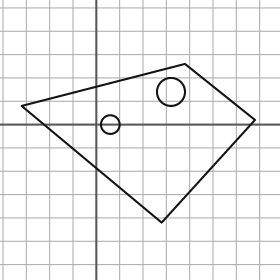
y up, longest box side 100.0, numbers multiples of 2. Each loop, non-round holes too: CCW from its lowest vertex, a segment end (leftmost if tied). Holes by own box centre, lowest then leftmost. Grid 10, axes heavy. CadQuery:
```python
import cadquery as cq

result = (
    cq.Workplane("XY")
    .moveTo(28.0, -42.0)
    .lineTo(68.0, 2.0)
    .lineTo(38.0, 26.0)
    .lineTo(-32.0, 8.0)
    .close()
    .moveTo(6.0, 0.0)
    .circle(4.0)
    .moveTo(32.0, 14.0)
    .circle(6.0)
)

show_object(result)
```